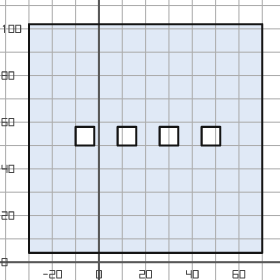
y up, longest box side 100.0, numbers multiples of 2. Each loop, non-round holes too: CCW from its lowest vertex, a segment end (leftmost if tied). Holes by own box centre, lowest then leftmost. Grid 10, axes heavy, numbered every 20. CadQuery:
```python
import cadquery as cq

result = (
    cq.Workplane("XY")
    .moveTo(-30.0, 4.0)
    .lineTo(70.0, 4.0)
    .lineTo(70.0, 102.0)
    .lineTo(-30.0, 102.0)
    .close()
    .moveTo(-10.0, 50.0)
    .lineTo(-2.0, 50.0)
    .lineTo(-2.0, 58.0)
    .lineTo(-10.0, 58.0)
    .close()
    .moveTo(8.0, 50.0)
    .lineTo(16.0, 50.0)
    .lineTo(16.0, 58.0)
    .lineTo(8.0, 58.0)
    .close()
    .moveTo(26.0, 50.0)
    .lineTo(34.0, 50.0)
    .lineTo(34.0, 58.0)
    .lineTo(26.0, 58.0)
    .close()
    .moveTo(44.0, 50.0)
    .lineTo(52.0, 50.0)
    .lineTo(52.0, 58.0)
    .lineTo(44.0, 58.0)
    .close()
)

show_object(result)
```